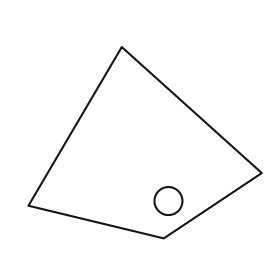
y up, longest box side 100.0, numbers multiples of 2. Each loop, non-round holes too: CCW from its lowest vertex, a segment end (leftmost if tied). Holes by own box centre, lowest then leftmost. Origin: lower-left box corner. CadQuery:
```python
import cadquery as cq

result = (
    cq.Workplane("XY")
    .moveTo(58.0, 0.0)
    .lineTo(100.0, 28.0)
    .lineTo(40.0, 82.0)
    .lineTo(0.0, 14.0)
    .close()
    .moveTo(60.0, 16.0)
    .circle(6.0)
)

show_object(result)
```